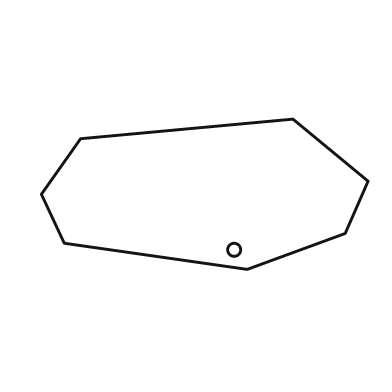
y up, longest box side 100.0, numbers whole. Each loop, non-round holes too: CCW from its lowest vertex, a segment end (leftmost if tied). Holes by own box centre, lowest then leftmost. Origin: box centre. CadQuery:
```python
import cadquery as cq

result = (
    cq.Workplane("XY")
    .moveTo(13.0, -23.0)
    .lineTo(43.0, -12.0)
    .lineTo(50.0, 4.0)
    .lineTo(27.0, 23.0)
    .lineTo(-38.0, 17.0)
    .lineTo(-50.0, 0.0)
    .lineTo(-43.0, -15.0)
    .close()
    .moveTo(9.0, -17.0)
    .circle(2.0)
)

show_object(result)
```